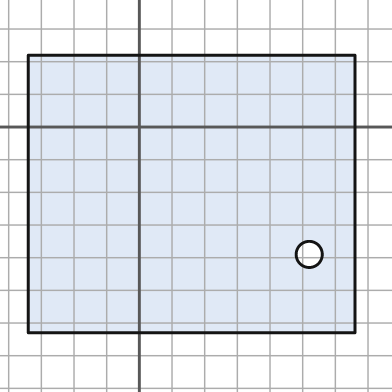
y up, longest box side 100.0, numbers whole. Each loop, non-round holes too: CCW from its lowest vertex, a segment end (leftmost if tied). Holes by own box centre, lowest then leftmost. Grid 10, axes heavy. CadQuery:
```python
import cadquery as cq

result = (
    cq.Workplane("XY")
    .moveTo(-34.0, -63.0)
    .lineTo(66.0, -63.0)
    .lineTo(66.0, 22.0)
    .lineTo(-34.0, 22.0)
    .close()
    .moveTo(52.0, -39.0)
    .circle(4.0)
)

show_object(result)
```